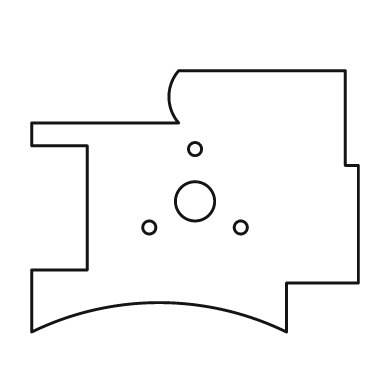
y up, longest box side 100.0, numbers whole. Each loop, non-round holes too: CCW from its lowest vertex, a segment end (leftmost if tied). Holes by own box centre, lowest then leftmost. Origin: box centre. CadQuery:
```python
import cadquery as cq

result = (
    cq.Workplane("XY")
    .moveTo(-50.0, -40.0)
    .threePointArc((-11.0, -31.0), (28.0, -40.0))
    .lineTo(28.0, -25.0)
    .lineTo(50.0, -25.0)
    .lineTo(50.0, 11.0)
    .lineTo(46.0, 11.0)
    .lineTo(46.0, 40.0)
    .lineTo(-5.0, 40.0)
    .threePointArc((-8.0, 32.0), (-5.0, 24.0))
    .lineTo(-50.0, 24.0)
    .lineTo(-50.0, 17.0)
    .lineTo(-33.0, 17.0)
    .lineTo(-33.0, -21.0)
    .lineTo(-50.0, -21.0)
    .close()
    .moveTo(-14.0, -8.0)
    .circle(2.0)
    .moveTo(14.0, -8.0)
    .circle(2.0)
    .moveTo(0.0, 0.0)
    .circle(6.0)
    .moveTo(0.0, 16.0)
    .circle(2.0)
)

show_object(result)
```